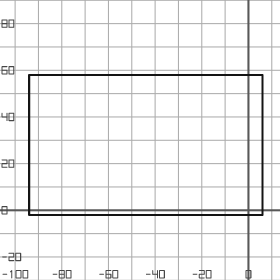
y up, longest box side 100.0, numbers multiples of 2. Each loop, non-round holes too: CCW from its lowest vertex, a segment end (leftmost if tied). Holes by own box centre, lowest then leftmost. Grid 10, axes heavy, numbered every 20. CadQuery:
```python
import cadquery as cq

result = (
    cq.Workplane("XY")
    .moveTo(-94.0, -2.0)
    .lineTo(6.0, -2.0)
    .lineTo(6.0, 58.0)
    .lineTo(-94.0, 58.0)
    .close()
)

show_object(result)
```